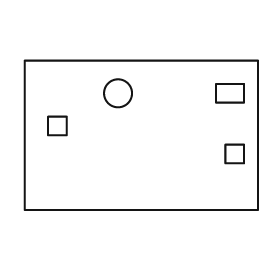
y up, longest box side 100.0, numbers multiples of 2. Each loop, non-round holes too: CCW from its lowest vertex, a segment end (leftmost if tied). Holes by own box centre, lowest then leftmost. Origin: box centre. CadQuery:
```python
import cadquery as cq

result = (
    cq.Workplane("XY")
    .moveTo(-50.0, -32.0)
    .lineTo(50.0, -32.0)
    .lineTo(50.0, 32.0)
    .lineTo(-50.0, 32.0)
    .close()
    .moveTo(36.0, -12.0)
    .lineTo(44.0, -12.0)
    .lineTo(44.0, -4.0)
    .lineTo(36.0, -4.0)
    .close()
    .moveTo(-40.0, 0.0)
    .lineTo(-32.0, 0.0)
    .lineTo(-32.0, 8.0)
    .lineTo(-40.0, 8.0)
    .close()
    .moveTo(-10.0, 18.0)
    .circle(6.0)
    .moveTo(32.0, 14.0)
    .lineTo(44.0, 14.0)
    .lineTo(44.0, 22.0)
    .lineTo(32.0, 22.0)
    .close()
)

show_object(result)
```